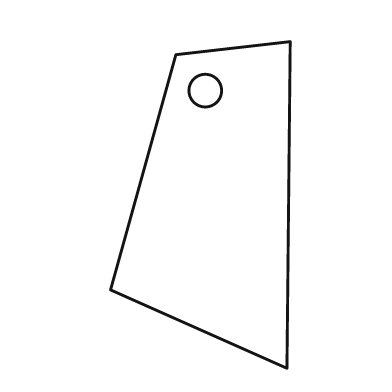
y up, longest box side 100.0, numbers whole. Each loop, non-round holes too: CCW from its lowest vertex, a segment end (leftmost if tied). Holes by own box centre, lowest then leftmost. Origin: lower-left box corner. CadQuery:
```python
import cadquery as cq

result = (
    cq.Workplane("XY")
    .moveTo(54.0, 0.0)
    .lineTo(55.0, 100.0)
    .lineTo(20.0, 96.0)
    .lineTo(0.0, 24.0)
    .close()
    .moveTo(29.0, 85.0)
    .circle(5.0)
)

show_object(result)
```